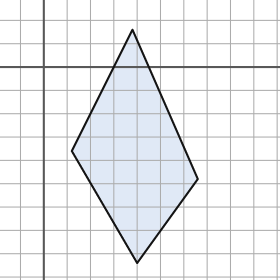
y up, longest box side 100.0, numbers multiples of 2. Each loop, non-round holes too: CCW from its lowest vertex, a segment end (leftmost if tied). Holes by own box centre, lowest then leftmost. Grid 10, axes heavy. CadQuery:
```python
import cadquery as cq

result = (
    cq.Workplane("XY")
    .moveTo(40.0, -84.0)
    .lineTo(66.0, -48.0)
    .lineTo(38.0, 16.0)
    .lineTo(12.0, -36.0)
    .close()
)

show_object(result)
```